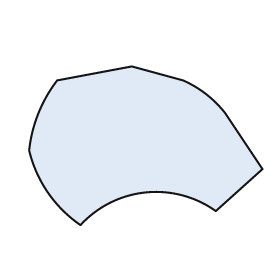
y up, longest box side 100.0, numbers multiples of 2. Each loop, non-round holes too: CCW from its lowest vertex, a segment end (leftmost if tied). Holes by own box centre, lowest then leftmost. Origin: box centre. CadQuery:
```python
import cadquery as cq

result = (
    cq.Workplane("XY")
    .moveTo(-28.0, -34.0)
    .threePointArc((0.0, -20.0), (30.0, -28.0))
    .lineTo(50.0, -10.0)
    .lineTo(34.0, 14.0)
    .threePointArc((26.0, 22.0), (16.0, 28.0))
    .lineTo(-6.0, 34.0)
    .lineTo(-38.0, 28.0)
    .threePointArc((-46.0, 14.0), (-50.0, -2.0))
    .threePointArc((-42.0, -20.0), (-28.0, -34.0))
    .close()
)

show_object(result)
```